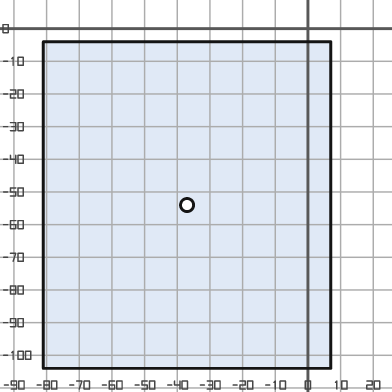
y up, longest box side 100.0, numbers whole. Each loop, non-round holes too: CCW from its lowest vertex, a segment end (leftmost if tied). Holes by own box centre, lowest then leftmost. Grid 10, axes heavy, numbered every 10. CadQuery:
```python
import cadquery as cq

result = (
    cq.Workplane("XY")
    .moveTo(-81.0, -104.0)
    .lineTo(7.0, -104.0)
    .lineTo(7.0, -4.0)
    .lineTo(-81.0, -4.0)
    .close()
    .moveTo(-37.0, -54.0)
    .circle(2.0)
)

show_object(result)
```